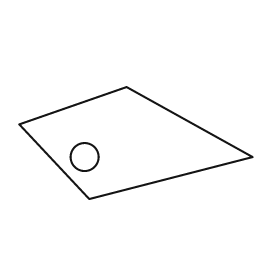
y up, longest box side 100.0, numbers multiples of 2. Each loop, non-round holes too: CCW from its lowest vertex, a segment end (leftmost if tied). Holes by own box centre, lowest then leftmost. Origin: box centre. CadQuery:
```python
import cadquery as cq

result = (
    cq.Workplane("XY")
    .moveTo(-20.0, -24.0)
    .lineTo(50.0, -6.0)
    .lineTo(-4.0, 24.0)
    .lineTo(-50.0, 8.0)
    .close()
    .moveTo(-22.0, -6.0)
    .circle(6.0)
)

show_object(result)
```